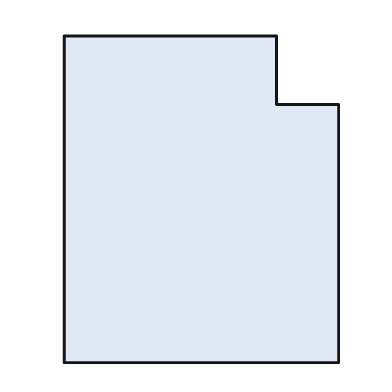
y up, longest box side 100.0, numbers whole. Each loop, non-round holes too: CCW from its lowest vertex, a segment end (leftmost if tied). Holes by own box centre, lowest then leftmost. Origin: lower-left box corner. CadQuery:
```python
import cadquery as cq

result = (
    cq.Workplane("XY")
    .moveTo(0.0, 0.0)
    .lineTo(84.0, 0.0)
    .lineTo(84.0, 79.0)
    .lineTo(65.0, 79.0)
    .lineTo(65.0, 100.0)
    .lineTo(0.0, 100.0)
    .close()
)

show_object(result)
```